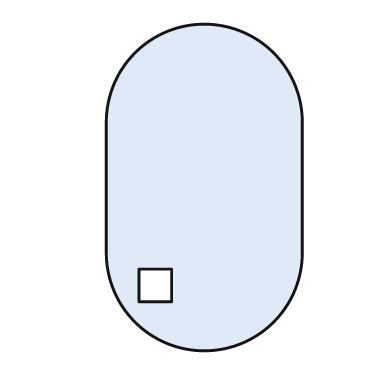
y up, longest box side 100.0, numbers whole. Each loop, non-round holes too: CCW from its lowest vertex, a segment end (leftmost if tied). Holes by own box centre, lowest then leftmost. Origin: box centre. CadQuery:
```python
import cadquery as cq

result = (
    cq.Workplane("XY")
    .moveTo(-30.0, -20.0)
    .threePointArc((0.0, -50.0), (30.0, -20.0))
    .lineTo(30.0, 20.0)
    .threePointArc((0.0, 50.0), (-30.0, 20.0))
    .close()
    .moveTo(-20.0, -35.0)
    .lineTo(-10.0, -35.0)
    .lineTo(-10.0, -25.0)
    .lineTo(-20.0, -25.0)
    .close()
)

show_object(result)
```